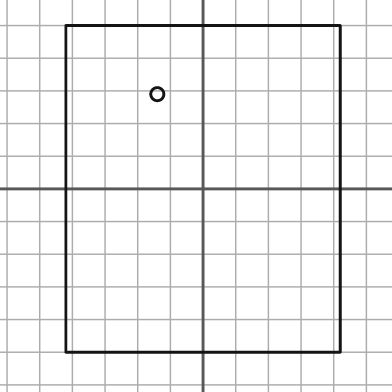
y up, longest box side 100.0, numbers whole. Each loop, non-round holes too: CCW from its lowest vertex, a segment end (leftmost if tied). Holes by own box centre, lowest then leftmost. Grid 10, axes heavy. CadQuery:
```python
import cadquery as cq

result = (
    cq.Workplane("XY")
    .moveTo(-42.0, -50.0)
    .lineTo(42.0, -50.0)
    .lineTo(42.0, 50.0)
    .lineTo(-42.0, 50.0)
    .close()
    .moveTo(-14.0, 29.0)
    .circle(2.0)
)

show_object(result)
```